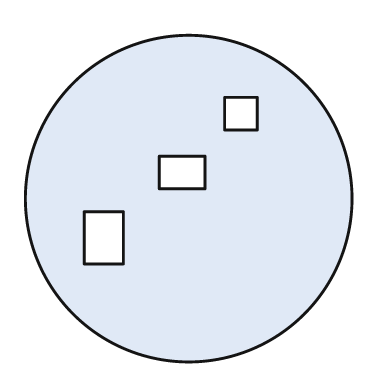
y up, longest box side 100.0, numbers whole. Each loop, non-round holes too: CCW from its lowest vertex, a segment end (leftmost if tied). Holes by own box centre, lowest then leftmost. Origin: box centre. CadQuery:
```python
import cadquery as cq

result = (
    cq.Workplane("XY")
    .moveTo(0.0, 0.0)
    .circle(50.0)
    .moveTo(-32.0, -20.0)
    .lineTo(-20.0, -20.0)
    .lineTo(-20.0, -4.0)
    .lineTo(-32.0, -4.0)
    .close()
    .moveTo(-9.0, 3.0)
    .lineTo(5.0, 3.0)
    .lineTo(5.0, 13.0)
    .lineTo(-9.0, 13.0)
    .close()
    .moveTo(11.0, 21.0)
    .lineTo(21.0, 21.0)
    .lineTo(21.0, 31.0)
    .lineTo(11.0, 31.0)
    .close()
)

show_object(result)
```